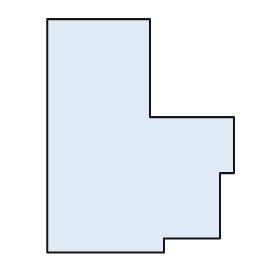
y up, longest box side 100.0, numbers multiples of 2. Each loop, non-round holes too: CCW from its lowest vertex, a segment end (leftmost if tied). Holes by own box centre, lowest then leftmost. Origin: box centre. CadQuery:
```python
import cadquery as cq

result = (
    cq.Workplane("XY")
    .moveTo(-40.0, -50.0)
    .lineTo(10.0, -50.0)
    .lineTo(10.0, -44.0)
    .lineTo(34.0, -44.0)
    .lineTo(34.0, -16.0)
    .lineTo(40.0, -16.0)
    .lineTo(40.0, 8.0)
    .lineTo(4.0, 8.0)
    .lineTo(4.0, 50.0)
    .lineTo(-40.0, 50.0)
    .close()
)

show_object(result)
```